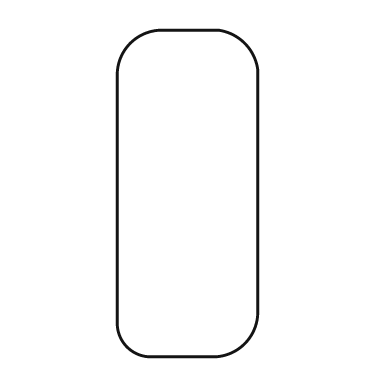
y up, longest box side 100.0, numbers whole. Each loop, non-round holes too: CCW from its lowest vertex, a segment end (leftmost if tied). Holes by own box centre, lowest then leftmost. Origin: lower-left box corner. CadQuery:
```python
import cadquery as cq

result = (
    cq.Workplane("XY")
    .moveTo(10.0, 0.0)
    .lineTo(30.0, 0.0)
    .threePointArc((39.0, 4.0), (43.0, 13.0))
    .lineTo(43.0, 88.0)
    .threePointArc((39.0, 96.0), (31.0, 100.0))
    .lineTo(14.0, 100.0)
    .threePointArc((4.0, 96.0), (0.0, 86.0))
    .lineTo(0.0, 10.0)
    .threePointArc((3.0, 3.0), (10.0, 0.0))
    .close()
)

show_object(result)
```